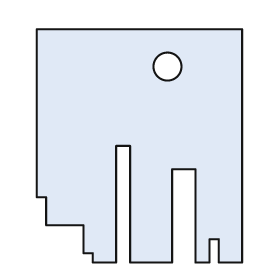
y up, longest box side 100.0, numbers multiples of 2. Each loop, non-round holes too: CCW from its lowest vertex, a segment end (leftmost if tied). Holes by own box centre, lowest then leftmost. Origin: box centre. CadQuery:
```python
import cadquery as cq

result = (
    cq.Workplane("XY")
    .moveTo(-20.0, -50.0)
    .lineTo(-10.0, -50.0)
    .lineTo(-10.0, 0.0)
    .lineTo(-4.0, 0.0)
    .lineTo(-4.0, -50.0)
    .lineTo(14.0, -50.0)
    .lineTo(14.0, -10.0)
    .lineTo(24.0, -10.0)
    .lineTo(24.0, -50.0)
    .lineTo(30.0, -50.0)
    .lineTo(30.0, -40.0)
    .lineTo(34.0, -40.0)
    .lineTo(34.0, -50.0)
    .lineTo(44.0, -50.0)
    .lineTo(44.0, 50.0)
    .lineTo(-44.0, 50.0)
    .lineTo(-44.0, -22.0)
    .lineTo(-40.0, -22.0)
    .lineTo(-40.0, -34.0)
    .lineTo(-24.0, -34.0)
    .lineTo(-24.0, -46.0)
    .lineTo(-20.0, -46.0)
    .close()
    .moveTo(12.0, 34.0)
    .circle(6.0)
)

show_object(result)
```